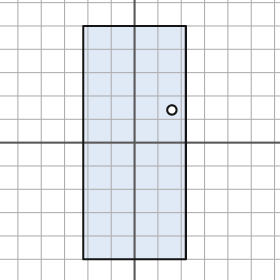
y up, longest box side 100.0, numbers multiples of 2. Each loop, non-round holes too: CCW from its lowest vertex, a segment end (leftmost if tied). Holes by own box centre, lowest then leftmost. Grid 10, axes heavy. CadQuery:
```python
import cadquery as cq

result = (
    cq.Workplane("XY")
    .moveTo(-22.0, -50.0)
    .lineTo(22.0, -50.0)
    .lineTo(22.0, 50.0)
    .lineTo(-22.0, 50.0)
    .close()
    .moveTo(16.0, 14.0)
    .circle(2.0)
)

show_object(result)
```